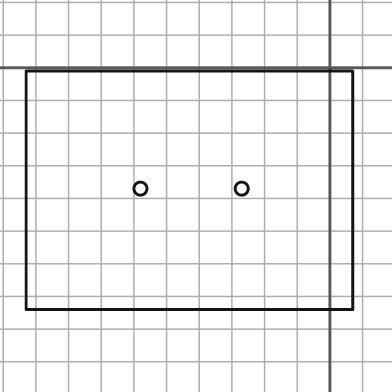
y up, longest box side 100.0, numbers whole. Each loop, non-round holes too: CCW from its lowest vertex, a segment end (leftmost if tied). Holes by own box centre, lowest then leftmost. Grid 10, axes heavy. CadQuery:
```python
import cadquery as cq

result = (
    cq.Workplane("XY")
    .moveTo(-93.0, -74.0)
    .lineTo(7.0, -74.0)
    .lineTo(7.0, -1.0)
    .lineTo(-93.0, -1.0)
    .close()
    .moveTo(-58.0, -37.0)
    .circle(2.0)
    .moveTo(-27.0, -37.0)
    .circle(2.0)
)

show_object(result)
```